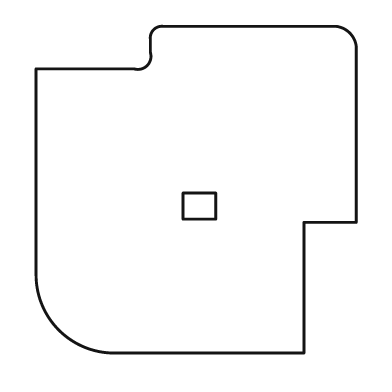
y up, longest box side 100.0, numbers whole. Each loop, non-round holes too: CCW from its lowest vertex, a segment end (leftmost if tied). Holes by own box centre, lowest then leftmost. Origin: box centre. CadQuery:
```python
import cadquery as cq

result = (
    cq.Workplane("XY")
    .moveTo(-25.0, -50.0)
    .lineTo(33.0, -50.0)
    .lineTo(33.0, -10.0)
    .lineTo(49.0, -10.0)
    .lineTo(49.0, 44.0)
    .threePointArc((47.0, 48.0), (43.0, 50.0))
    .lineTo(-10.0, 50.0)
    .threePointArc((-13.0, 49.0), (-14.0, 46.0))
    .lineTo(-14.0, 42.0)
    .threePointArc((-15.0, 38.0), (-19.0, 37.0))
    .lineTo(-49.0, 37.0)
    .lineTo(-49.0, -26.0)
    .threePointArc((-42.0, -43.0), (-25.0, -50.0))
    .close()
    .moveTo(-4.0, -9.0)
    .lineTo(6.0, -9.0)
    .lineTo(6.0, -1.0)
    .lineTo(-4.0, -1.0)
    .close()
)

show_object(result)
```